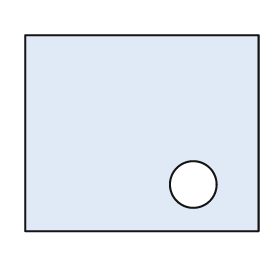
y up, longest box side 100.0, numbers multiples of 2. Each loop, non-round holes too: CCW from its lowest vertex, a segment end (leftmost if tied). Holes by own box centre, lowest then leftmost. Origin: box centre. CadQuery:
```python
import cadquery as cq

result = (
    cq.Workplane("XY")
    .moveTo(-50.0, -42.0)
    .lineTo(50.0, -42.0)
    .lineTo(50.0, 42.0)
    .lineTo(-50.0, 42.0)
    .close()
    .moveTo(22.0, -22.0)
    .circle(10.0)
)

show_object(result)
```